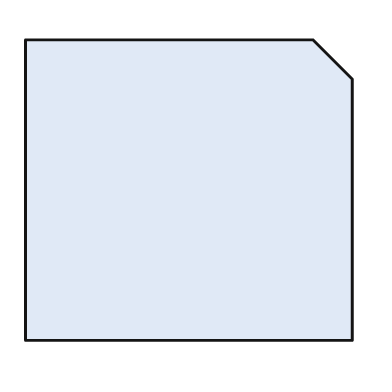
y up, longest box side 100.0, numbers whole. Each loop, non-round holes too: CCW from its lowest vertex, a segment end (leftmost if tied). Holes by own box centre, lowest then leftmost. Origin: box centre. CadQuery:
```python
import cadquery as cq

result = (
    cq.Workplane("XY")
    .moveTo(-50.0, -46.0)
    .lineTo(50.0, -46.0)
    .lineTo(50.0, 34.0)
    .lineTo(38.0, 46.0)
    .lineTo(-50.0, 46.0)
    .close()
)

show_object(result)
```